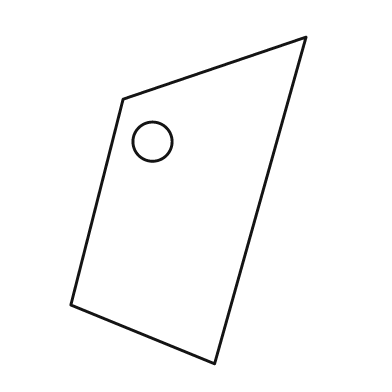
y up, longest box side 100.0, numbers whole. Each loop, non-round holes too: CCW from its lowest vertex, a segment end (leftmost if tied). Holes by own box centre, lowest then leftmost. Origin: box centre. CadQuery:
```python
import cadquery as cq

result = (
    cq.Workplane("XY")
    .moveTo(8.0, -50.0)
    .lineTo(36.0, 50.0)
    .lineTo(-20.0, 31.0)
    .lineTo(-36.0, -32.0)
    .close()
    .moveTo(-11.0, 18.0)
    .circle(6.0)
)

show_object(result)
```